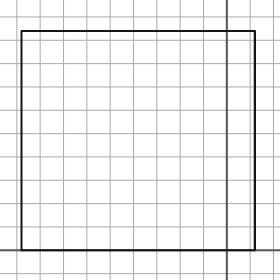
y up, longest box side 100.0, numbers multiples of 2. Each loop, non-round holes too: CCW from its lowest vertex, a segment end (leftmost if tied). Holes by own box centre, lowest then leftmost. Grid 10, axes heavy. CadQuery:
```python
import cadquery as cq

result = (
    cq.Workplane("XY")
    .moveTo(-88.0, 0.0)
    .lineTo(12.0, 0.0)
    .lineTo(12.0, 94.0)
    .lineTo(-88.0, 94.0)
    .close()
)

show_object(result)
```